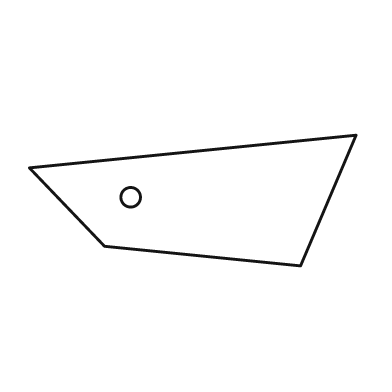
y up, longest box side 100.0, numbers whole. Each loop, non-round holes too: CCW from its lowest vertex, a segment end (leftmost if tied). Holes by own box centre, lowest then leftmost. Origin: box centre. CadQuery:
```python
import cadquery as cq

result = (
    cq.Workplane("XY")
    .moveTo(33.0, -20.0)
    .lineTo(50.0, 20.0)
    .lineTo(-50.0, 10.0)
    .lineTo(-27.0, -14.0)
    .close()
    .moveTo(-19.0, 1.0)
    .circle(3.0)
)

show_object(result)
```